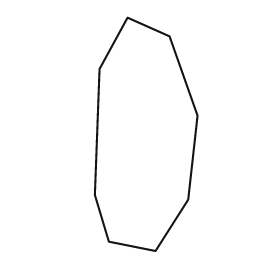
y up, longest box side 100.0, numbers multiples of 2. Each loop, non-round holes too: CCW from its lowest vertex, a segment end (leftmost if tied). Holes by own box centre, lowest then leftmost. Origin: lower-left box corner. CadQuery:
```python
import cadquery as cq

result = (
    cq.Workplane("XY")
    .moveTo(26.0, 0.0)
    .lineTo(40.0, 22.0)
    .lineTo(44.0, 58.0)
    .lineTo(32.0, 92.0)
    .lineTo(14.0, 100.0)
    .lineTo(2.0, 78.0)
    .lineTo(0.0, 24.0)
    .lineTo(6.0, 4.0)
    .close()
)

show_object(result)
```